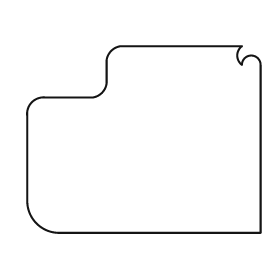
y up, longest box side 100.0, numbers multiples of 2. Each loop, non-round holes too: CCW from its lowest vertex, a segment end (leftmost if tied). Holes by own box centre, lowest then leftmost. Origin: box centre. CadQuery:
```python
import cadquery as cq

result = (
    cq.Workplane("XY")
    .moveTo(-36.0, -40.0)
    .lineTo(50.0, -40.0)
    .lineTo(50.0, 32.0)
    .threePointArc((46.0, 36.0), (42.0, 32.0))
    .threePointArc((40.0, 36.0), (42.0, 40.0))
    .lineTo(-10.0, 40.0)
    .threePointArc((-14.0, 38.0), (-16.0, 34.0))
    .lineTo(-16.0, 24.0)
    .threePointArc((-18.0, 20.0), (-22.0, 18.0))
    .lineTo(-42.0, 18.0)
    .threePointArc((-48.0, 16.0), (-50.0, 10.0))
    .lineTo(-50.0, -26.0)
    .threePointArc((-46.0, -36.0), (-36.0, -40.0))
    .close()
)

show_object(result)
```